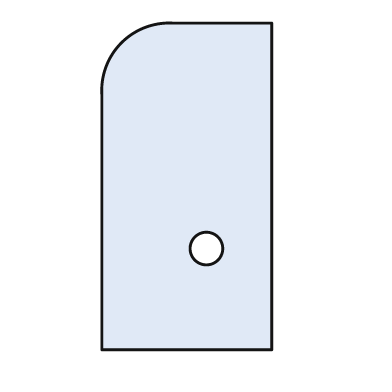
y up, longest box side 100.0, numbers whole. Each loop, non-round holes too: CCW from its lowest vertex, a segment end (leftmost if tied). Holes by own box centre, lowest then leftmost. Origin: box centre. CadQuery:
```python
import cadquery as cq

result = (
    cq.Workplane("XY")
    .moveTo(-26.0, -50.0)
    .lineTo(26.0, -50.0)
    .lineTo(26.0, 50.0)
    .lineTo(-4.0, 50.0)
    .threePointArc((-20.0, 44.0), (-26.0, 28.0))
    .close()
    .moveTo(6.0, -19.0)
    .circle(5.0)
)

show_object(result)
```